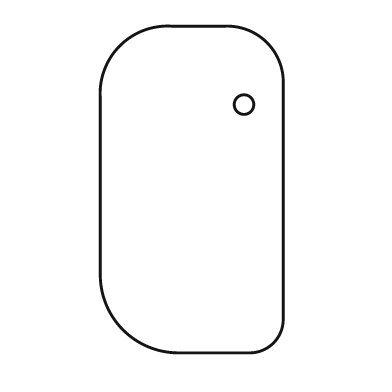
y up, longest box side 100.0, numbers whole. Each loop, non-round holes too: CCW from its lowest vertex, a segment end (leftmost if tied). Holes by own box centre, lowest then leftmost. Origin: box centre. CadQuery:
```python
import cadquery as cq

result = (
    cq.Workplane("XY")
    .moveTo(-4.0, -50.0)
    .lineTo(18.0, -50.0)
    .threePointArc((25.0, -47.0), (28.0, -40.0))
    .lineTo(28.0, 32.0)
    .threePointArc((23.0, 45.0), (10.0, 50.0))
    .lineTo(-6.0, 50.0)
    .threePointArc((-22.0, 44.0), (-28.0, 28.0))
    .lineTo(-28.0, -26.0)
    .threePointArc((-21.0, -43.0), (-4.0, -50.0))
    .close()
    .moveTo(16.0, 26.0)
    .circle(3.0)
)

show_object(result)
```